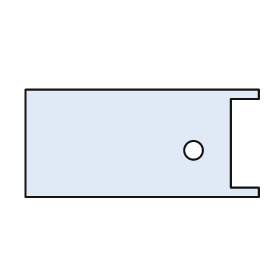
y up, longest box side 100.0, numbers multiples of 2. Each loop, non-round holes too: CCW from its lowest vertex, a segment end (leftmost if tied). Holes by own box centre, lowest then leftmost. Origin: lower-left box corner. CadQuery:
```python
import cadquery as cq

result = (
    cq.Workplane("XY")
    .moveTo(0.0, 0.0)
    .lineTo(100.0, 0.0)
    .lineTo(100.0, 4.0)
    .lineTo(88.0, 4.0)
    .lineTo(88.0, 42.0)
    .lineTo(100.0, 42.0)
    .lineTo(100.0, 46.0)
    .lineTo(0.0, 46.0)
    .close()
    .moveTo(72.0, 20.0)
    .circle(4.0)
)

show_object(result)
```